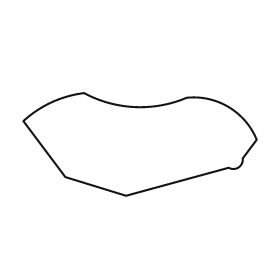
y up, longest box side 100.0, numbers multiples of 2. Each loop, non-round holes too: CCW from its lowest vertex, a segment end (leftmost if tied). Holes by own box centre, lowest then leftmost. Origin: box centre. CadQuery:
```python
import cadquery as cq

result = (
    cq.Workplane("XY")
    .moveTo(-6.0, -22.0)
    .lineTo(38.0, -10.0)
    .threePointArc((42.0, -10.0), (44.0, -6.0))
    .lineTo(50.0, 2.0)
    .threePointArc((38.0, 16.0), (20.0, 20.0))
    .threePointArc((-2.0, 16.0), (-24.0, 22.0))
    .threePointArc((-38.0, 18.0), (-50.0, 10.0))
    .lineTo(-32.0, -14.0)
    .close()
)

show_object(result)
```